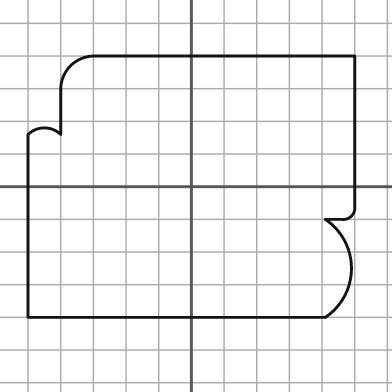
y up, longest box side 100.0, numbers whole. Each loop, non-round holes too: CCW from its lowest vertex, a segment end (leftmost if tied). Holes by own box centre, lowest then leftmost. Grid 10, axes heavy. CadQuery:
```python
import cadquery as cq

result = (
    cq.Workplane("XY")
    .moveTo(-50.0, -40.0)
    .lineTo(41.0, -40.0)
    .threePointArc((49.0, -25.0), (41.0, -10.0))
    .lineTo(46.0, -10.0)
    .threePointArc((49.0, -9.0), (50.0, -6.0))
    .lineTo(50.0, 40.0)
    .lineTo(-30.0, 40.0)
    .threePointArc((-37.0, 37.0), (-40.0, 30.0))
    .lineTo(-40.0, 16.0)
    .threePointArc((-45.0, 18.0), (-50.0, 16.0))
    .close()
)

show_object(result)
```